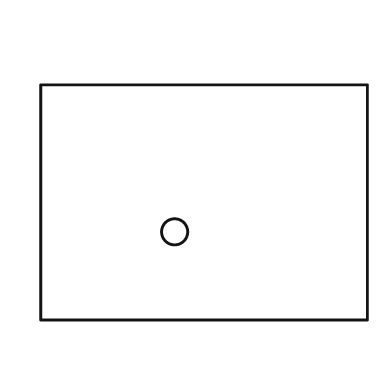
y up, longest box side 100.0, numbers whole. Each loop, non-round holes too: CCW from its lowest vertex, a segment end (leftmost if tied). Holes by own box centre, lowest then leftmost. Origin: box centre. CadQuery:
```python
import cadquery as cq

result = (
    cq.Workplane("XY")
    .moveTo(-50.0, -36.0)
    .lineTo(50.0, -36.0)
    .lineTo(50.0, 36.0)
    .lineTo(-50.0, 36.0)
    .close()
    .moveTo(-9.0, -9.0)
    .circle(4.0)
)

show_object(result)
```